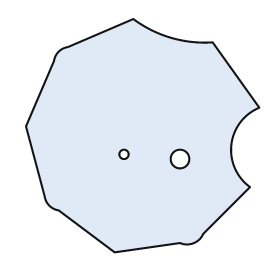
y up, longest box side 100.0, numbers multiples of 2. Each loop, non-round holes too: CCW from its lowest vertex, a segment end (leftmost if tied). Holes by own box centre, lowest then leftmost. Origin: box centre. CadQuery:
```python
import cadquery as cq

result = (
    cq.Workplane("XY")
    .moveTo(-12.0, -50.0)
    .lineTo(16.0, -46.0)
    .threePointArc((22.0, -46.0), (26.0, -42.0))
    .lineTo(46.0, -22.0)
    .threePointArc((38.0, -4.0), (50.0, 12.0))
    .lineTo(30.0, 40.0)
    .threePointArc((12.0, 42.0), (-4.0, 50.0))
    .lineTo(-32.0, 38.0)
    .threePointArc((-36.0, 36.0), (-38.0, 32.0))
    .lineTo(-50.0, 4.0)
    .lineTo(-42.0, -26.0)
    .threePointArc((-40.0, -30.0), (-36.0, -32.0))
    .close()
    .moveTo(16.0, -10.0)
    .circle(4.0)
    .moveTo(-8.0, -8.0)
    .circle(2.0)
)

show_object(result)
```